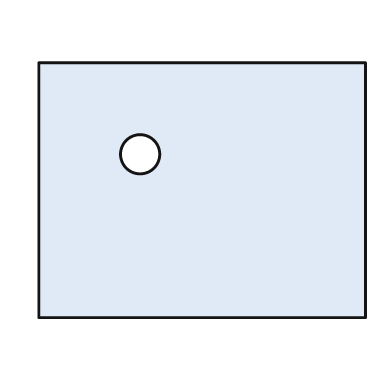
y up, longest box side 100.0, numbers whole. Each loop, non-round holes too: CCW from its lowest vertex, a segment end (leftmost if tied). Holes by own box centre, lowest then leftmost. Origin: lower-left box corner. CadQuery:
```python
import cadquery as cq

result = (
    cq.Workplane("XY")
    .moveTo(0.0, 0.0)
    .lineTo(100.0, 0.0)
    .lineTo(100.0, 78.0)
    .lineTo(0.0, 78.0)
    .close()
    .moveTo(31.0, 50.0)
    .circle(6.0)
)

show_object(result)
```